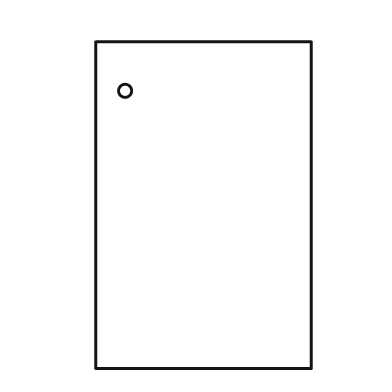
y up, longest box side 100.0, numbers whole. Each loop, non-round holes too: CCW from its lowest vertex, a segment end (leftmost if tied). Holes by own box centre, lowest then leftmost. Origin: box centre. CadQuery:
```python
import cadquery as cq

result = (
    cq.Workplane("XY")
    .moveTo(-33.0, -50.0)
    .lineTo(33.0, -50.0)
    .lineTo(33.0, 50.0)
    .lineTo(-33.0, 50.0)
    .close()
    .moveTo(-24.0, 35.0)
    .circle(2.0)
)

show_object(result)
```